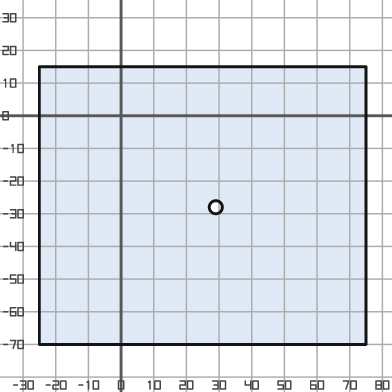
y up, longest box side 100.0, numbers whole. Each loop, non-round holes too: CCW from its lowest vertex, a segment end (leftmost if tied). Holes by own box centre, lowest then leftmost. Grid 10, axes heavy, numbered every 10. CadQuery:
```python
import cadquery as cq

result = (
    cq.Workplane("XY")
    .moveTo(-25.0, -70.0)
    .lineTo(75.0, -70.0)
    .lineTo(75.0, 15.0)
    .lineTo(-25.0, 15.0)
    .close()
    .moveTo(29.0, -28.0)
    .circle(2.0)
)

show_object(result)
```